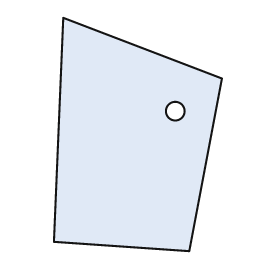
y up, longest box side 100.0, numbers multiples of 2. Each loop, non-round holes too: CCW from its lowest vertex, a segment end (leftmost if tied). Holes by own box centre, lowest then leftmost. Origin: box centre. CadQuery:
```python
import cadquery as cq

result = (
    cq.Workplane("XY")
    .moveTo(22.0, -50.0)
    .lineTo(36.0, 24.0)
    .lineTo(-32.0, 50.0)
    .lineTo(-36.0, -46.0)
    .close()
    .moveTo(16.0, 10.0)
    .circle(4.0)
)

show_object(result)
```